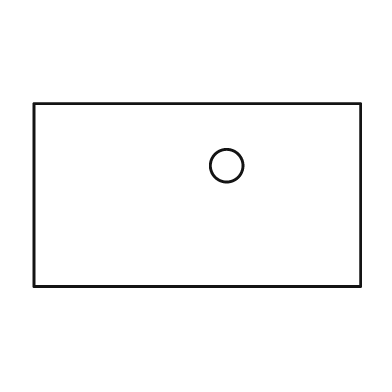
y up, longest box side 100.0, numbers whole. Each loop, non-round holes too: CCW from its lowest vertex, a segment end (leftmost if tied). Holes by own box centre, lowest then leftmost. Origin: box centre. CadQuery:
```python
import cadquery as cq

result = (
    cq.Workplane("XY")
    .moveTo(-50.0, -28.0)
    .lineTo(50.0, -28.0)
    .lineTo(50.0, 28.0)
    .lineTo(-50.0, 28.0)
    .close()
    .moveTo(9.0, 9.0)
    .circle(5.0)
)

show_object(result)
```